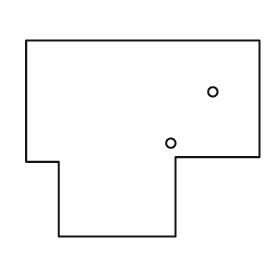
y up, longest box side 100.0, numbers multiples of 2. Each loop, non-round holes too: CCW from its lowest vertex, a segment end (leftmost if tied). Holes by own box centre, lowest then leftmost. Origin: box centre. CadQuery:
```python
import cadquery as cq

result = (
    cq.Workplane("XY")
    .moveTo(-36.0, -42.0)
    .lineTo(14.0, -42.0)
    .lineTo(14.0, -8.0)
    .lineTo(50.0, -8.0)
    .lineTo(50.0, 42.0)
    .lineTo(-50.0, 42.0)
    .lineTo(-50.0, -10.0)
    .lineTo(-36.0, -10.0)
    .close()
    .moveTo(12.0, -2.0)
    .circle(2.0)
    .moveTo(30.0, 20.0)
    .circle(2.0)
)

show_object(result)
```